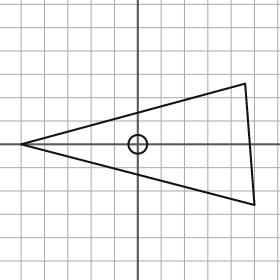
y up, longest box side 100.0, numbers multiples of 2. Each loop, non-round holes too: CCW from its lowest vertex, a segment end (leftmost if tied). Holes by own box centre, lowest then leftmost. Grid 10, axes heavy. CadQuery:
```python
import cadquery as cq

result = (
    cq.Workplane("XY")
    .moveTo(50.0, -26.0)
    .lineTo(46.0, 26.0)
    .lineTo(-50.0, 0.0)
    .close()
    .moveTo(0.0, 0.0)
    .circle(4.0)
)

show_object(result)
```